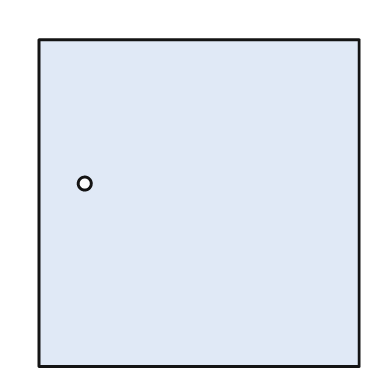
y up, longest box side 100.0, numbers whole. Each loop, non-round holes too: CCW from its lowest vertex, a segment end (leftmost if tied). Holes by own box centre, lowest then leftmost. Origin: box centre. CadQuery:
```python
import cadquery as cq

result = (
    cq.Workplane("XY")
    .moveTo(-49.0, -50.0)
    .lineTo(49.0, -50.0)
    .lineTo(49.0, 50.0)
    .lineTo(-49.0, 50.0)
    .close()
    .moveTo(-35.0, 6.0)
    .circle(2.0)
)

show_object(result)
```